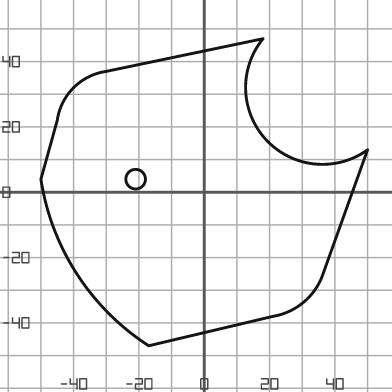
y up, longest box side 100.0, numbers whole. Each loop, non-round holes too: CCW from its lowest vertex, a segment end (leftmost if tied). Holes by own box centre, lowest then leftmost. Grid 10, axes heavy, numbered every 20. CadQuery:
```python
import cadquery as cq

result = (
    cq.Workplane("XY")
    .moveTo(-17.0, -47.0)
    .lineTo(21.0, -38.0)
    .threePointArc((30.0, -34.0), (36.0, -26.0))
    .lineTo(50.0, 13.0)
    .threePointArc((19.0, 16.0), (18.0, 47.0))
    .lineTo(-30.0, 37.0)
    .threePointArc((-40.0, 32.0), (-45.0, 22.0))
    .lineTo(-50.0, 4.0)
    .threePointArc((-39.0, -25.0), (-17.0, -47.0))
    .close()
    .moveTo(-21.0, 4.0)
    .circle(3.0)
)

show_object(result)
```